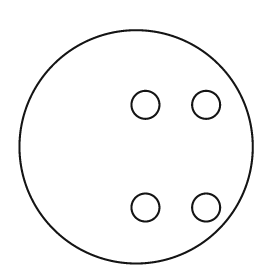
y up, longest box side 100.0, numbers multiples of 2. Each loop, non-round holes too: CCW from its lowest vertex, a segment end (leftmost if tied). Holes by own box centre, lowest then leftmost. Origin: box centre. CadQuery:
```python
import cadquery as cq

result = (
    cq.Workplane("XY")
    .moveTo(0.0, 0.0)
    .circle(50.0)
    .moveTo(4.0, -26.0)
    .circle(6.0)
    .moveTo(30.0, -26.0)
    .circle(6.0)
    .moveTo(4.0, 18.0)
    .circle(6.0)
    .moveTo(30.0, 18.0)
    .circle(6.0)
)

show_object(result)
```